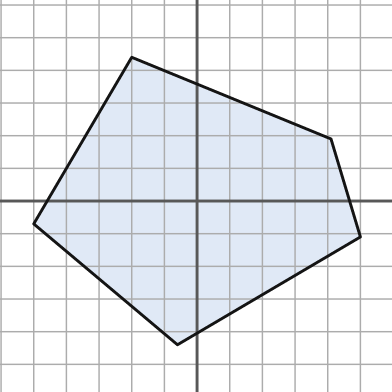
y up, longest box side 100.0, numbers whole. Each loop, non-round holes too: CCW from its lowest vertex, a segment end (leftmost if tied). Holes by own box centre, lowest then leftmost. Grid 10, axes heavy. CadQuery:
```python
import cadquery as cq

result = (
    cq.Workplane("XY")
    .moveTo(-6.0, -44.0)
    .lineTo(50.0, -11.0)
    .lineTo(41.0, 19.0)
    .lineTo(-20.0, 44.0)
    .lineTo(-50.0, -7.0)
    .close()
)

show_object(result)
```